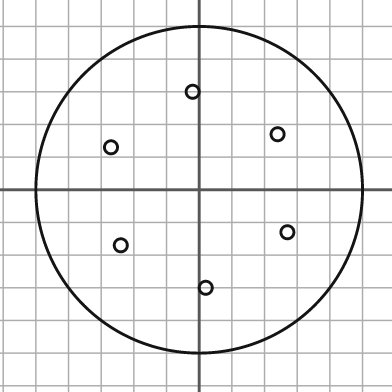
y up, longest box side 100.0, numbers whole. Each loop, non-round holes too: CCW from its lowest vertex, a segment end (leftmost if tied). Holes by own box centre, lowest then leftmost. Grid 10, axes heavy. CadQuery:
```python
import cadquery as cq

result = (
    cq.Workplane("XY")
    .moveTo(0.0, 0.0)
    .circle(50.0)
    .moveTo(2.0, -30.0)
    .circle(2.0)
    .moveTo(-24.0, -17.0)
    .circle(2.0)
    .moveTo(27.0, -13.0)
    .circle(2.0)
    .moveTo(-27.0, 13.0)
    .circle(2.0)
    .moveTo(24.0, 17.0)
    .circle(2.0)
    .moveTo(-2.0, 30.0)
    .circle(2.0)
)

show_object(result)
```